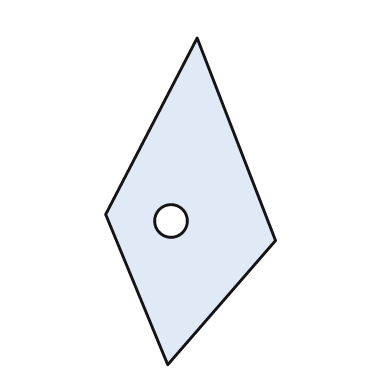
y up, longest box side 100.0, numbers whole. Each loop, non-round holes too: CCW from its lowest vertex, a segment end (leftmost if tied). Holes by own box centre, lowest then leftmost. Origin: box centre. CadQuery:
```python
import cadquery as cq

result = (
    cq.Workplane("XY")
    .moveTo(-7.0, -50.0)
    .lineTo(26.0, -12.0)
    .lineTo(2.0, 50.0)
    .lineTo(-26.0, -4.0)
    .close()
    .moveTo(-6.0, -6.0)
    .circle(5.0)
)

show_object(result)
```